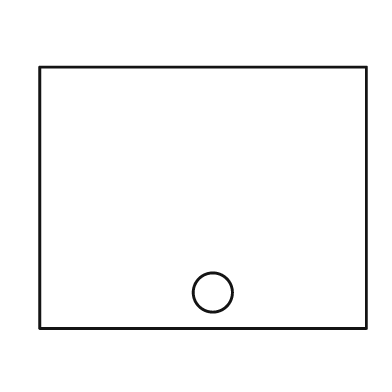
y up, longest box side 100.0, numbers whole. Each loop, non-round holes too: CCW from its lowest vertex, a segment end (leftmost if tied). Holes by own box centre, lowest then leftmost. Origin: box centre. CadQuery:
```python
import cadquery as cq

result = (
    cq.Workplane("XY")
    .moveTo(-50.0, -40.0)
    .lineTo(50.0, -40.0)
    .lineTo(50.0, 40.0)
    .lineTo(-50.0, 40.0)
    .close()
    .moveTo(3.0, -29.0)
    .circle(6.0)
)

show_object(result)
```